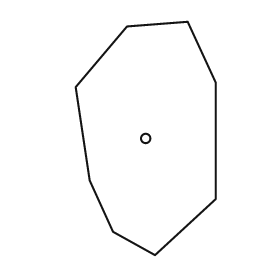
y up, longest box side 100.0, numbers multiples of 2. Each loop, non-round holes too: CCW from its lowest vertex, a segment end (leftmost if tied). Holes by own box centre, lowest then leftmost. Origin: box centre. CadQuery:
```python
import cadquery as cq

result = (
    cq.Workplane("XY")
    .moveTo(4.0, -50.0)
    .lineTo(30.0, -26.0)
    .lineTo(30.0, 24.0)
    .lineTo(18.0, 50.0)
    .lineTo(-8.0, 48.0)
    .lineTo(-30.0, 22.0)
    .lineTo(-24.0, -18.0)
    .lineTo(-14.0, -40.0)
    .close()
    .moveTo(0.0, 0.0)
    .circle(2.0)
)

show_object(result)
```